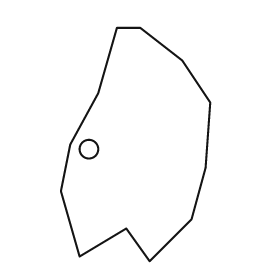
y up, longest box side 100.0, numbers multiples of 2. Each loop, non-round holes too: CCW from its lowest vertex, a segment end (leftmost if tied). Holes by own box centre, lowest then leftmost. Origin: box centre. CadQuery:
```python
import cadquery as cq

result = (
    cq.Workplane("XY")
    .moveTo(6.0, -50.0)
    .lineTo(24.0, -32.0)
    .lineTo(30.0, -10.0)
    .lineTo(32.0, 18.0)
    .lineTo(20.0, 36.0)
    .lineTo(2.0, 50.0)
    .lineTo(-8.0, 50.0)
    .lineTo(-16.0, 22.0)
    .lineTo(-28.0, 0.0)
    .lineTo(-32.0, -20.0)
    .lineTo(-24.0, -48.0)
    .lineTo(-4.0, -36.0)
    .close()
    .moveTo(-20.0, -2.0)
    .circle(4.0)
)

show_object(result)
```